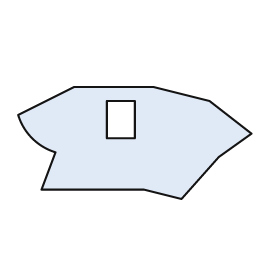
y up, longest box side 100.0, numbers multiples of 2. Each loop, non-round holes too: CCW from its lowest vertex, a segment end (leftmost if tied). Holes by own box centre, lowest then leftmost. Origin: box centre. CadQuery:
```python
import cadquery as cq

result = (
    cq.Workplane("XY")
    .moveTo(20.0, -24.0)
    .lineTo(36.0, -6.0)
    .lineTo(50.0, 4.0)
    .lineTo(32.0, 18.0)
    .lineTo(8.0, 24.0)
    .lineTo(-26.0, 24.0)
    .lineTo(-50.0, 12.0)
    .threePointArc((-44.0, 2.0), (-34.0, -4.0))
    .lineTo(-40.0, -20.0)
    .lineTo(4.0, -20.0)
    .close()
    .moveTo(-12.0, 2.0)
    .lineTo(0.0, 2.0)
    .lineTo(0.0, 18.0)
    .lineTo(-12.0, 18.0)
    .close()
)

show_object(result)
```